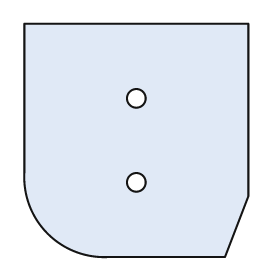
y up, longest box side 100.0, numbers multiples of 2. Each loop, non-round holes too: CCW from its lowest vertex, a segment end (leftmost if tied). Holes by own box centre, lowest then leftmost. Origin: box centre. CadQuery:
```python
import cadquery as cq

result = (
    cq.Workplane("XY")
    .moveTo(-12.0, -50.0)
    .lineTo(38.0, -50.0)
    .lineTo(48.0, -24.0)
    .lineTo(48.0, 50.0)
    .lineTo(-48.0, 50.0)
    .lineTo(-48.0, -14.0)
    .threePointArc((-38.0, -40.0), (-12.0, -50.0))
    .close()
    .moveTo(0.0, -18.0)
    .circle(4.0)
    .moveTo(0.0, 18.0)
    .circle(4.0)
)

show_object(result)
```